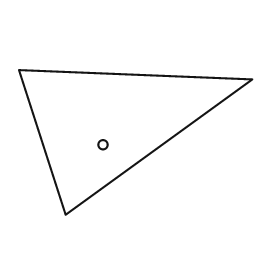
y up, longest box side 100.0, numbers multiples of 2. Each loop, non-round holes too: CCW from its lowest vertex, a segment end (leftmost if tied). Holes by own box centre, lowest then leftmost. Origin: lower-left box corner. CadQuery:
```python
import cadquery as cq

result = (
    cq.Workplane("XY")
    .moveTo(20.0, 0.0)
    .lineTo(100.0, 58.0)
    .lineTo(0.0, 62.0)
    .close()
    .moveTo(36.0, 30.0)
    .circle(2.0)
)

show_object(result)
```